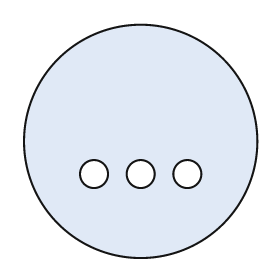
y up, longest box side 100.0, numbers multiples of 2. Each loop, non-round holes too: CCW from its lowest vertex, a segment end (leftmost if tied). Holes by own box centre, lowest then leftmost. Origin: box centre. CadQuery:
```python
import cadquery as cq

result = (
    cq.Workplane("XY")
    .moveTo(0.0, 0.0)
    .circle(50.0)
    .moveTo(-20.0, -14.0)
    .circle(6.0)
    .moveTo(0.0, -14.0)
    .circle(6.0)
    .moveTo(20.0, -14.0)
    .circle(6.0)
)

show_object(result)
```